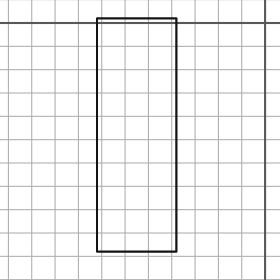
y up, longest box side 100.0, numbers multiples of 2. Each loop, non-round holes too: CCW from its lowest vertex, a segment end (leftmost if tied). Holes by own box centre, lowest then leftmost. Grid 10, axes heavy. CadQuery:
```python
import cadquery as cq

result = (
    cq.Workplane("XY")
    .moveTo(-72.0, -98.0)
    .lineTo(-38.0, -98.0)
    .lineTo(-38.0, 2.0)
    .lineTo(-72.0, 2.0)
    .close()
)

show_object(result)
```